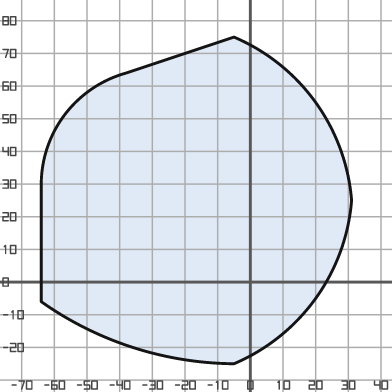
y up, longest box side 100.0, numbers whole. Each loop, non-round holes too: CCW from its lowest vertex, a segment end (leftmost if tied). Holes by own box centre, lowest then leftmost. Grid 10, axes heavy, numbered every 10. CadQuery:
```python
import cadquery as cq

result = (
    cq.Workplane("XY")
    .moveTo(-5.0, -25.0)
    .threePointArc((20.0, -5.0), (31.0, 25.0))
    .threePointArc((20.0, 55.0), (-5.0, 75.0))
    .lineTo(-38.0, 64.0)
    .threePointArc((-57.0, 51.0), (-64.0, 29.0))
    .lineTo(-64.0, -6.0)
    .threePointArc((-36.0, -20.0), (-5.0, -25.0))
    .close()
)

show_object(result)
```